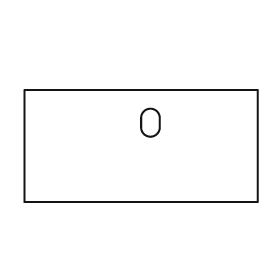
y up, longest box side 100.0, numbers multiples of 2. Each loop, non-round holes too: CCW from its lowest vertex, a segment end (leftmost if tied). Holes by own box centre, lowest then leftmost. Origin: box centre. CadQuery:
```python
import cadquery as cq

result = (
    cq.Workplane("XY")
    .moveTo(-50.0, -24.0)
    .lineTo(50.0, -24.0)
    .lineTo(50.0, 24.0)
    .lineTo(-50.0, 24.0)
    .close()
    .moveTo(0.0, 8.0)
    .threePointArc((4.0, 4.0), (8.0, 8.0))
    .lineTo(8.0, 12.0)
    .threePointArc((4.0, 16.0), (0.0, 12.0))
    .close()
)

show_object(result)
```